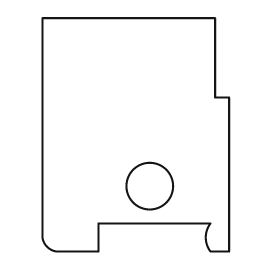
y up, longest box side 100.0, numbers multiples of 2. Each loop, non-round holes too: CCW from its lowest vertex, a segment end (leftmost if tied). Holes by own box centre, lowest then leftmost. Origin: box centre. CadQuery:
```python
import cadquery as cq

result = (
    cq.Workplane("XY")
    .moveTo(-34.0, -50.0)
    .lineTo(-16.0, -50.0)
    .lineTo(-16.0, -38.0)
    .lineTo(32.0, -38.0)
    .threePointArc((30.0, -44.0), (32.0, -50.0))
    .lineTo(40.0, -50.0)
    .lineTo(40.0, 16.0)
    .lineTo(34.0, 16.0)
    .lineTo(34.0, 50.0)
    .lineTo(-40.0, 50.0)
    .lineTo(-40.0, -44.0)
    .threePointArc((-38.0, -48.0), (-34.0, -50.0))
    .close()
    .moveTo(6.0, -22.0)
    .circle(10.0)
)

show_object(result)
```